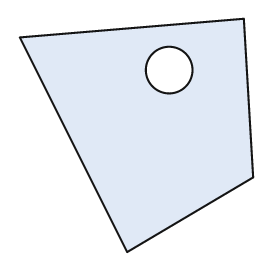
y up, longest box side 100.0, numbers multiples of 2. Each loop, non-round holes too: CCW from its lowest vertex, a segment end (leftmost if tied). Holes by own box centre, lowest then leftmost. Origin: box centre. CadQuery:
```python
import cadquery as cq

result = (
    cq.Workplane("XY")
    .moveTo(-4.0, -50.0)
    .lineTo(50.0, -18.0)
    .lineTo(46.0, 50.0)
    .lineTo(-50.0, 42.0)
    .close()
    .moveTo(14.0, 28.0)
    .circle(10.0)
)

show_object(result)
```